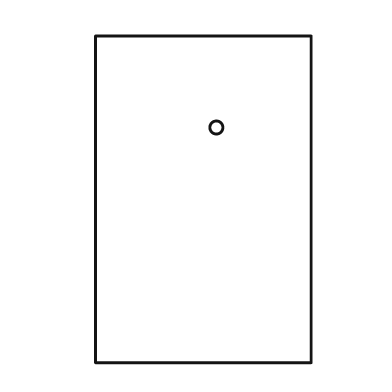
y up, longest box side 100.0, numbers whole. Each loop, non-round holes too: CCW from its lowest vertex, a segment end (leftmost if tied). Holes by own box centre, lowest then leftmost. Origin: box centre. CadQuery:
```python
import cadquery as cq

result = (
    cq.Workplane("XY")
    .moveTo(-33.0, -50.0)
    .lineTo(33.0, -50.0)
    .lineTo(33.0, 50.0)
    .lineTo(-33.0, 50.0)
    .close()
    .moveTo(4.0, 22.0)
    .circle(2.0)
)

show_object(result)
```